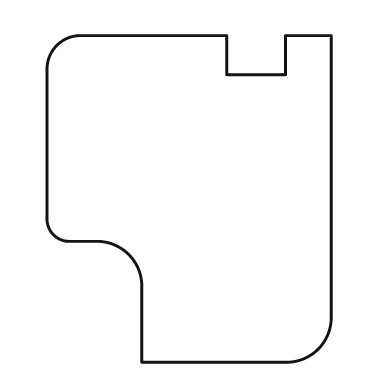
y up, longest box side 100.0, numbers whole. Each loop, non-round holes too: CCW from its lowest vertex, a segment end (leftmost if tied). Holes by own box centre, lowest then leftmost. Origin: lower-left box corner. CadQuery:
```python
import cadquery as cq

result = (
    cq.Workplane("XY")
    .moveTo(29.0, 0.0)
    .lineTo(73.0, 0.0)
    .threePointArc((83.0, 4.0), (87.0, 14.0))
    .lineTo(87.0, 100.0)
    .lineTo(73.0, 100.0)
    .lineTo(73.0, 88.0)
    .lineTo(55.0, 88.0)
    .lineTo(55.0, 100.0)
    .lineTo(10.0, 100.0)
    .threePointArc((3.0, 97.0), (0.0, 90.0))
    .lineTo(0.0, 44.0)
    .threePointArc((2.0, 39.0), (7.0, 37.0))
    .lineTo(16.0, 37.0)
    .threePointArc((25.0, 33.0), (29.0, 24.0))
    .close()
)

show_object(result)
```